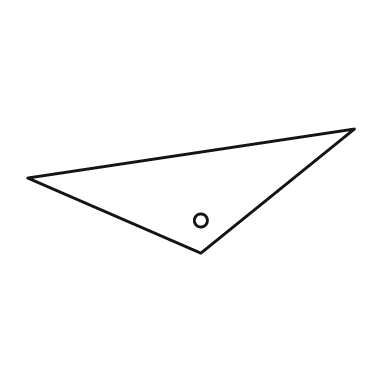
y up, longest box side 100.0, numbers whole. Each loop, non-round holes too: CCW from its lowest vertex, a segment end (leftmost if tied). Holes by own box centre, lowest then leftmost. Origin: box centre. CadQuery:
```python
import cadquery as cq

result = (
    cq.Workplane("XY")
    .moveTo(3.0, -19.0)
    .lineTo(50.0, 19.0)
    .lineTo(-50.0, 4.0)
    .close()
    .moveTo(3.0, -9.0)
    .circle(2.0)
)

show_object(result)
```